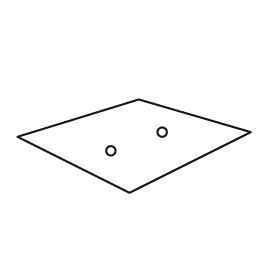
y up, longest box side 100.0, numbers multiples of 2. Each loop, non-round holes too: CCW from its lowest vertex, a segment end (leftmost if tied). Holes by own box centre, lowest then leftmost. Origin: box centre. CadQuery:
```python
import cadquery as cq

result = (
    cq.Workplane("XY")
    .moveTo(-2.0, -20.0)
    .lineTo(50.0, 6.0)
    .lineTo(2.0, 20.0)
    .lineTo(-50.0, 4.0)
    .close()
    .moveTo(-10.0, -2.0)
    .circle(2.0)
    .moveTo(12.0, 6.0)
    .circle(2.0)
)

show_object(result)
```